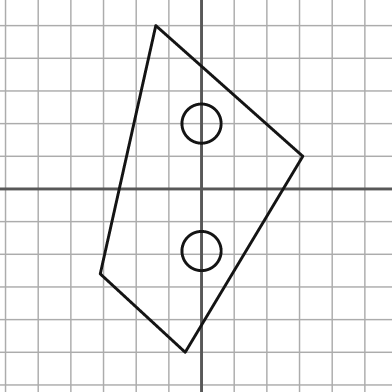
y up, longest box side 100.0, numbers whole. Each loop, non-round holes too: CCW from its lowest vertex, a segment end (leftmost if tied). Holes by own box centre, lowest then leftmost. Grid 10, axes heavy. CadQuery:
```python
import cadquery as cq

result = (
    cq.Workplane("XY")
    .moveTo(-5.0, -50.0)
    .lineTo(31.0, 10.0)
    .lineTo(-14.0, 50.0)
    .lineTo(-31.0, -26.0)
    .close()
    .moveTo(0.0, -19.0)
    .circle(6.0)
    .moveTo(0.0, 20.0)
    .circle(6.0)
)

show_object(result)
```